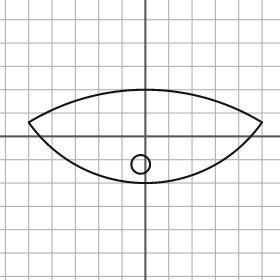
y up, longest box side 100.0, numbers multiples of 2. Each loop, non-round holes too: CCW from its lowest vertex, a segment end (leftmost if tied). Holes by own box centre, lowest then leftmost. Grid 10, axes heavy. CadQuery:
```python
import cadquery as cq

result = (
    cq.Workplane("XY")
    .moveTo(-50.0, 6.0)
    .threePointArc((0.0, -20.0), (50.0, 6.0))
    .threePointArc((0.0, 20.0), (-50.0, 6.0))
    .close()
    .moveTo(-2.0, -12.0)
    .circle(4.0)
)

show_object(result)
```